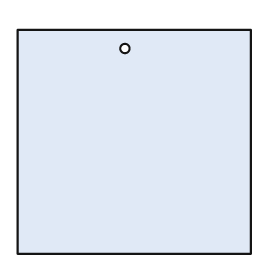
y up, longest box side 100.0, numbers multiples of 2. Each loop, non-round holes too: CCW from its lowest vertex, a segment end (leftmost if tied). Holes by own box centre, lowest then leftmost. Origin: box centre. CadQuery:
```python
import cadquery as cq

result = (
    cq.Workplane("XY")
    .moveTo(-50.0, -48.0)
    .lineTo(50.0, -48.0)
    .lineTo(50.0, 48.0)
    .lineTo(-50.0, 48.0)
    .close()
    .moveTo(-4.0, 40.0)
    .circle(2.0)
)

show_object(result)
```